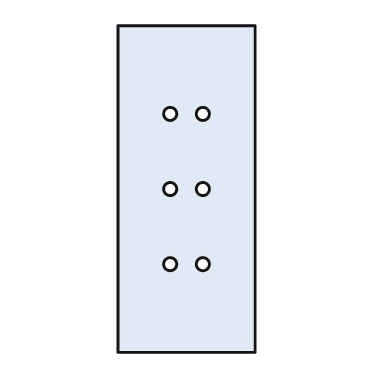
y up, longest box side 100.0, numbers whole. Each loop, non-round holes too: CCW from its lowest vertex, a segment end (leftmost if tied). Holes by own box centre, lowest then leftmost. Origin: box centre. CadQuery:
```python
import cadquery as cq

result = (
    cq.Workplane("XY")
    .moveTo(-21.0, -50.0)
    .lineTo(21.0, -50.0)
    .lineTo(21.0, 50.0)
    .lineTo(-21.0, 50.0)
    .close()
    .moveTo(-5.0, -23.0)
    .circle(2.0)
    .moveTo(5.0, -23.0)
    .circle(2.0)
    .moveTo(-5.0, 0.0)
    .circle(2.0)
    .moveTo(5.0, 0.0)
    .circle(2.0)
    .moveTo(-5.0, 23.0)
    .circle(2.0)
    .moveTo(5.0, 23.0)
    .circle(2.0)
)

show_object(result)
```